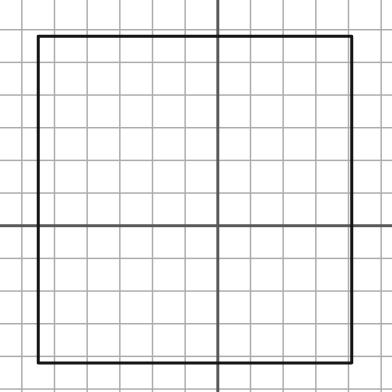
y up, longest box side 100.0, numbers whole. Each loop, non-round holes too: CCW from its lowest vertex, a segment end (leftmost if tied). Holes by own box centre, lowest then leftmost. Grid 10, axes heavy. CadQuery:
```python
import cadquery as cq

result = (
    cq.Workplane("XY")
    .moveTo(-55.0, -42.0)
    .lineTo(41.0, -42.0)
    .lineTo(41.0, 58.0)
    .lineTo(-55.0, 58.0)
    .close()
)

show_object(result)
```